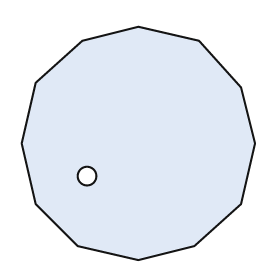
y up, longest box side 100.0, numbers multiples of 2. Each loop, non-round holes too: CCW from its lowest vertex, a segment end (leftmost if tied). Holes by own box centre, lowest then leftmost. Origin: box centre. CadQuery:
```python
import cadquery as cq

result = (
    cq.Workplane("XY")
    .moveTo(0.0, -50.0)
    .lineTo(24.0, -44.0)
    .lineTo(44.0, -26.0)
    .lineTo(50.0, 0.0)
    .lineTo(44.0, 24.0)
    .lineTo(26.0, 44.0)
    .lineTo(0.0, 50.0)
    .lineTo(-24.0, 44.0)
    .lineTo(-44.0, 26.0)
    .lineTo(-50.0, 0.0)
    .lineTo(-44.0, -26.0)
    .lineTo(-26.0, -44.0)
    .close()
    .moveTo(-22.0, -14.0)
    .circle(4.0)
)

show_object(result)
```